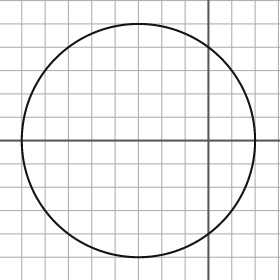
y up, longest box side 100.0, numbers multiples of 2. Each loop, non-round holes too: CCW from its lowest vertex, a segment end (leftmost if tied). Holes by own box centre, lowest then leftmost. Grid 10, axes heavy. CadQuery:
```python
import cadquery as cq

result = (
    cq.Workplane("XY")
    .moveTo(-30.0, 0.0)
    .circle(50.0)
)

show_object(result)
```